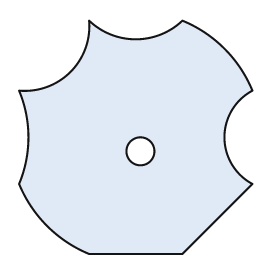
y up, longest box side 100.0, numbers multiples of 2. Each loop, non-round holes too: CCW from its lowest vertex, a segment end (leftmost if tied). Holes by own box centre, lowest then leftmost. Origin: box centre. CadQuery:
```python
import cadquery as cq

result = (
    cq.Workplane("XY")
    .moveTo(-20.0, -50.0)
    .lineTo(20.0, -50.0)
    .lineTo(50.0, -20.0)
    .threePointArc((38.0, 0.0), (50.0, 20.0))
    .threePointArc((38.0, 38.0), (20.0, 50.0))
    .threePointArc((0.0, 42.0), (-20.0, 50.0))
    .threePointArc((-28.0, 28.0), (-50.0, 20.0))
    .threePointArc((-46.0, 0.0), (-50.0, -20.0))
    .threePointArc((-38.0, -38.0), (-20.0, -50.0))
    .close()
    .moveTo(2.0, -6.0)
    .circle(6.0)
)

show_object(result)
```